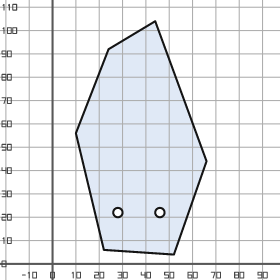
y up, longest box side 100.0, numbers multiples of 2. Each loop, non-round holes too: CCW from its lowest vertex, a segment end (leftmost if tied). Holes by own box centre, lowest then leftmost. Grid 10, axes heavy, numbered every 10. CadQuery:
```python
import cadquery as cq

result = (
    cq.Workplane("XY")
    .moveTo(52.0, 4.0)
    .lineTo(66.0, 44.0)
    .lineTo(44.0, 104.0)
    .lineTo(24.0, 92.0)
    .lineTo(10.0, 56.0)
    .lineTo(22.0, 6.0)
    .close()
    .moveTo(28.0, 22.0)
    .circle(2.0)
    .moveTo(46.0, 22.0)
    .circle(2.0)
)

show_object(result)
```